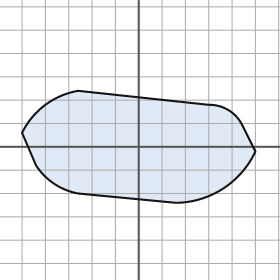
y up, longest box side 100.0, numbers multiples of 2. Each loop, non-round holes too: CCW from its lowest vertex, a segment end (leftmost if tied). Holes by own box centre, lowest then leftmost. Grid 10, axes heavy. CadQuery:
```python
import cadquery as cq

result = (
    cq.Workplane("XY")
    .moveTo(16.0, -24.0)
    .threePointArc((36.0, -18.0), (50.0, -2.0))
    .lineTo(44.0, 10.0)
    .threePointArc((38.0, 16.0), (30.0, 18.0))
    .lineTo(-26.0, 24.0)
    .threePointArc((-40.0, 18.0), (-50.0, 6.0))
    .lineTo(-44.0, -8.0)
    .threePointArc((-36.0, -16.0), (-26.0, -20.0))
    .close()
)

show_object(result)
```